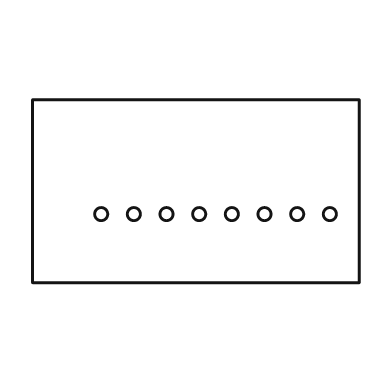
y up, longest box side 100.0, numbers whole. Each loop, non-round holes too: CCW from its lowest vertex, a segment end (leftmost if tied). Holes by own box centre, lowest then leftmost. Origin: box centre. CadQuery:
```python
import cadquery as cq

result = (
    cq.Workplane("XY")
    .moveTo(-50.0, -28.0)
    .lineTo(50.0, -28.0)
    .lineTo(50.0, 28.0)
    .lineTo(-50.0, 28.0)
    .close()
    .moveTo(-29.0, -7.0)
    .circle(2.0)
    .moveTo(-19.0, -7.0)
    .circle(2.0)
    .moveTo(-9.0, -7.0)
    .circle(2.0)
    .moveTo(1.0, -7.0)
    .circle(2.0)
    .moveTo(11.0, -7.0)
    .circle(2.0)
    .moveTo(21.0, -7.0)
    .circle(2.0)
    .moveTo(31.0, -7.0)
    .circle(2.0)
    .moveTo(41.0, -7.0)
    .circle(2.0)
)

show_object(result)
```